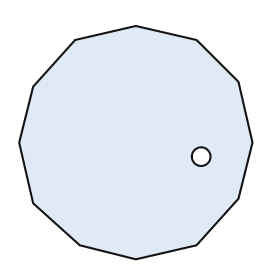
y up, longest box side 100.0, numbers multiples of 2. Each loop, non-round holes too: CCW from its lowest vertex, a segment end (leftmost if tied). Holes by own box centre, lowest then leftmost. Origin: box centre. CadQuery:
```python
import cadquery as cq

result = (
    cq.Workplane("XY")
    .moveTo(0.0, -50.0)
    .lineTo(26.0, -44.0)
    .lineTo(44.0, -24.0)
    .lineTo(50.0, 0.0)
    .lineTo(44.0, 26.0)
    .lineTo(26.0, 44.0)
    .lineTo(0.0, 50.0)
    .lineTo(-26.0, 44.0)
    .lineTo(-44.0, 24.0)
    .lineTo(-50.0, 0.0)
    .lineTo(-44.0, -26.0)
    .lineTo(-24.0, -44.0)
    .close()
    .moveTo(28.0, -6.0)
    .circle(4.0)
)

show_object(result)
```